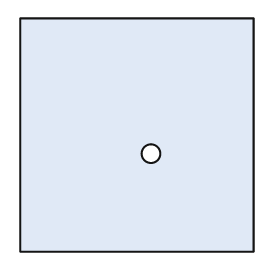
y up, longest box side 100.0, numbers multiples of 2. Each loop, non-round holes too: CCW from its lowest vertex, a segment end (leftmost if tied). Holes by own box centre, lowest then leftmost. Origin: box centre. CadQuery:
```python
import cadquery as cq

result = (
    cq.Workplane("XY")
    .moveTo(-50.0, -50.0)
    .lineTo(50.0, -50.0)
    .lineTo(50.0, 50.0)
    .lineTo(-50.0, 50.0)
    .close()
    .moveTo(6.0, -8.0)
    .circle(4.0)
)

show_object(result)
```